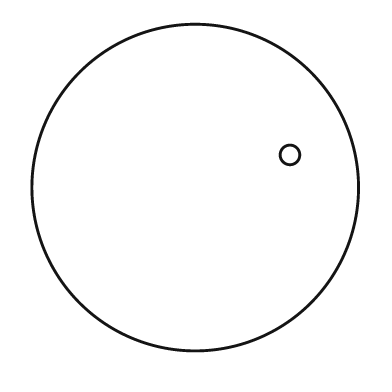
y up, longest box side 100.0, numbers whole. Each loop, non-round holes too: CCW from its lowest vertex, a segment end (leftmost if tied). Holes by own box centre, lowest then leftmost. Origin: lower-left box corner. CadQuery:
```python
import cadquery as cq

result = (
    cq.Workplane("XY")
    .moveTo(50.0, 50.0)
    .circle(50.0)
    .moveTo(79.0, 60.0)
    .circle(3.0)
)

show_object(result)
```